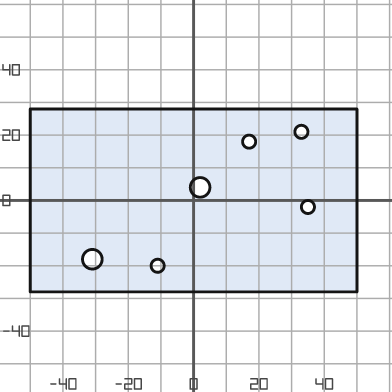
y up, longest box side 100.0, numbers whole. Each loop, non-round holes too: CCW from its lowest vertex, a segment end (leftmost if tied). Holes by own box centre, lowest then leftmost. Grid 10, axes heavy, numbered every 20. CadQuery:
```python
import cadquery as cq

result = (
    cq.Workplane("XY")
    .moveTo(-50.0, -28.0)
    .lineTo(50.0, -28.0)
    .lineTo(50.0, 28.0)
    .lineTo(-50.0, 28.0)
    .close()
    .moveTo(-11.0, -20.0)
    .circle(2.0)
    .moveTo(-31.0, -18.0)
    .circle(3.0)
    .moveTo(35.0, -2.0)
    .circle(2.0)
    .moveTo(2.0, 4.0)
    .circle(3.0)
    .moveTo(17.0, 18.0)
    .circle(2.0)
    .moveTo(33.0, 21.0)
    .circle(2.0)
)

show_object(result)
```